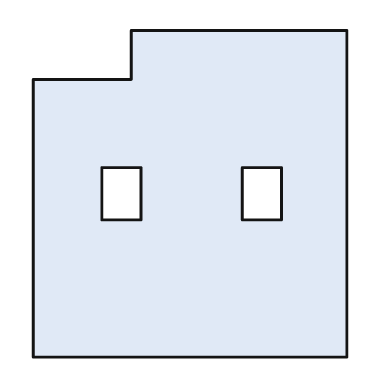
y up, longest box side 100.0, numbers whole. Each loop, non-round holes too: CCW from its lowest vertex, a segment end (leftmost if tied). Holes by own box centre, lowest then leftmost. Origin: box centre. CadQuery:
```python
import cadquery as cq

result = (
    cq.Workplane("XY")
    .moveTo(-48.0, -50.0)
    .lineTo(48.0, -50.0)
    .lineTo(48.0, 50.0)
    .lineTo(-18.0, 50.0)
    .lineTo(-18.0, 35.0)
    .lineTo(-48.0, 35.0)
    .close()
    .moveTo(-27.0, -8.0)
    .lineTo(-15.0, -8.0)
    .lineTo(-15.0, 8.0)
    .lineTo(-27.0, 8.0)
    .close()
    .moveTo(16.0, -8.0)
    .lineTo(28.0, -8.0)
    .lineTo(28.0, 8.0)
    .lineTo(16.0, 8.0)
    .close()
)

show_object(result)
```